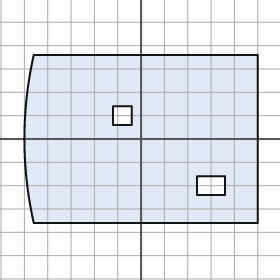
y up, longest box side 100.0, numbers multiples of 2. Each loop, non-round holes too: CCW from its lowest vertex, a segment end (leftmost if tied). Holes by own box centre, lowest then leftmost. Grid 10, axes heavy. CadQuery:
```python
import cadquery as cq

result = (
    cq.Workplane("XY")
    .moveTo(-46.0, -36.0)
    .lineTo(50.0, -36.0)
    .lineTo(50.0, 36.0)
    .lineTo(-46.0, 36.0)
    .threePointArc((-50.0, 0.0), (-46.0, -36.0))
    .close()
    .moveTo(24.0, -24.0)
    .lineTo(36.0, -24.0)
    .lineTo(36.0, -16.0)
    .lineTo(24.0, -16.0)
    .close()
    .moveTo(-12.0, 6.0)
    .lineTo(-4.0, 6.0)
    .lineTo(-4.0, 14.0)
    .lineTo(-12.0, 14.0)
    .close()
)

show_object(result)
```